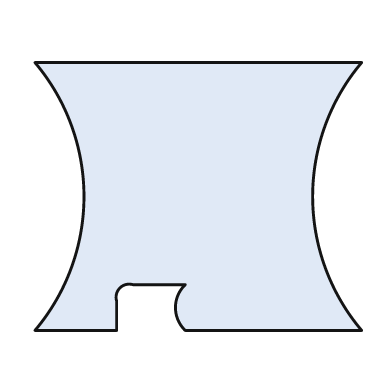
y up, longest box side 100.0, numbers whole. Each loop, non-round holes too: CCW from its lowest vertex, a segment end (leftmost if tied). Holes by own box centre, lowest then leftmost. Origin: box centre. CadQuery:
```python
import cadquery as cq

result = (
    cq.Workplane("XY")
    .moveTo(-50.0, -41.0)
    .lineTo(-25.0, -41.0)
    .lineTo(-25.0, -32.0)
    .threePointArc((-24.0, -28.0), (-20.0, -27.0))
    .lineTo(-4.0, -27.0)
    .threePointArc((-7.0, -34.0), (-4.0, -41.0))
    .lineTo(50.0, -41.0)
    .threePointArc((35.0, 0.0), (50.0, 41.0))
    .lineTo(-50.0, 41.0)
    .threePointArc((-35.0, 0.0), (-50.0, -41.0))
    .close()
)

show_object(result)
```